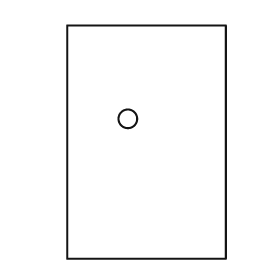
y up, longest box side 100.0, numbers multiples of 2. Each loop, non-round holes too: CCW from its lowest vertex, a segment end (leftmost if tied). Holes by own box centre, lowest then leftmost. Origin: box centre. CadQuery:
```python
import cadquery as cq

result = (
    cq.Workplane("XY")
    .moveTo(-34.0, -50.0)
    .lineTo(34.0, -50.0)
    .lineTo(34.0, 50.0)
    .lineTo(-34.0, 50.0)
    .close()
    .moveTo(-8.0, 10.0)
    .circle(4.0)
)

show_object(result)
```